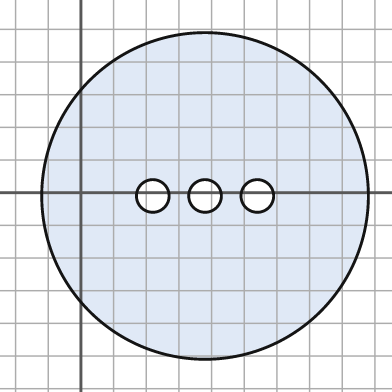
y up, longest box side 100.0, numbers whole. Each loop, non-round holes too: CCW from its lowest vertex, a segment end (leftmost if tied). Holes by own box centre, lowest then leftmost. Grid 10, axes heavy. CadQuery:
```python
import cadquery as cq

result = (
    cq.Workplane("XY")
    .moveTo(38.0, -1.0)
    .circle(50.0)
    .moveTo(22.0, -1.0)
    .circle(5.0)
    .moveTo(38.0, -1.0)
    .circle(5.0)
    .moveTo(54.0, -1.0)
    .circle(5.0)
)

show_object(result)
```